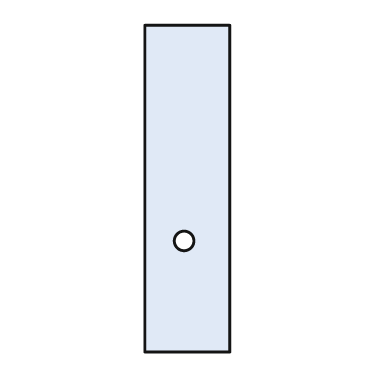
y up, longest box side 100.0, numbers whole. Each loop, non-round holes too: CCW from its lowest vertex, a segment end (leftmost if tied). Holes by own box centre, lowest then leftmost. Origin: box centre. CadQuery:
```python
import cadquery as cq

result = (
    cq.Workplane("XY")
    .moveTo(-13.0, -50.0)
    .lineTo(13.0, -50.0)
    .lineTo(13.0, 50.0)
    .lineTo(-13.0, 50.0)
    .close()
    .moveTo(-1.0, -16.0)
    .circle(3.0)
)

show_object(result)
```